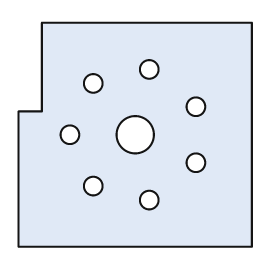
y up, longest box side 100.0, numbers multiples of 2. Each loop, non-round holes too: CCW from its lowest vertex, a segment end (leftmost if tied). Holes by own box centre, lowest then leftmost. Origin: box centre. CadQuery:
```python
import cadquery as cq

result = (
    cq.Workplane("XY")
    .moveTo(-50.0, -48.0)
    .lineTo(50.0, -48.0)
    .lineTo(50.0, 48.0)
    .lineTo(-40.0, 48.0)
    .lineTo(-40.0, 10.0)
    .lineTo(-50.0, 10.0)
    .close()
    .moveTo(6.0, -28.0)
    .circle(4.0)
    .moveTo(-18.0, -22.0)
    .circle(4.0)
    .moveTo(26.0, -12.0)
    .circle(4.0)
    .moveTo(-28.0, 0.0)
    .circle(4.0)
    .moveTo(0.0, 0.0)
    .circle(8.0)
    .moveTo(26.0, 12.0)
    .circle(4.0)
    .moveTo(-18.0, 22.0)
    .circle(4.0)
    .moveTo(6.0, 28.0)
    .circle(4.0)
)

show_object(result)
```